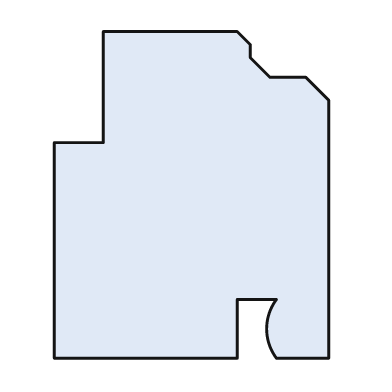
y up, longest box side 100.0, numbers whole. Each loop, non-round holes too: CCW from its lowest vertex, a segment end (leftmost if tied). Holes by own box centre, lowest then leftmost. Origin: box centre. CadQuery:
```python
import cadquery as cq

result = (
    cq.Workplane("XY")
    .moveTo(-42.0, -50.0)
    .lineTo(14.0, -50.0)
    .lineTo(14.0, -32.0)
    .lineTo(26.0, -32.0)
    .threePointArc((23.0, -41.0), (26.0, -50.0))
    .lineTo(42.0, -50.0)
    .lineTo(42.0, 29.0)
    .lineTo(35.0, 36.0)
    .lineTo(24.0, 36.0)
    .lineTo(18.0, 42.0)
    .lineTo(18.0, 46.0)
    .lineTo(14.0, 50.0)
    .lineTo(-27.0, 50.0)
    .lineTo(-27.0, 16.0)
    .lineTo(-42.0, 16.0)
    .close()
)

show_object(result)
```